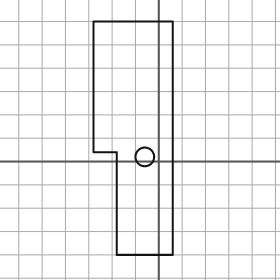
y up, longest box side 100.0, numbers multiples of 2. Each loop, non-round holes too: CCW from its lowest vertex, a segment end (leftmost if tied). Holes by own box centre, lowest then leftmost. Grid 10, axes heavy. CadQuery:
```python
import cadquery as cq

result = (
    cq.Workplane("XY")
    .moveTo(-18.0, -40.0)
    .lineTo(6.0, -40.0)
    .lineTo(6.0, 60.0)
    .lineTo(-28.0, 60.0)
    .lineTo(-28.0, 4.0)
    .lineTo(-18.0, 4.0)
    .close()
    .moveTo(-6.0, 2.0)
    .circle(4.0)
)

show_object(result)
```